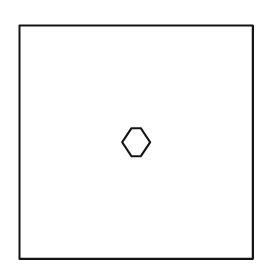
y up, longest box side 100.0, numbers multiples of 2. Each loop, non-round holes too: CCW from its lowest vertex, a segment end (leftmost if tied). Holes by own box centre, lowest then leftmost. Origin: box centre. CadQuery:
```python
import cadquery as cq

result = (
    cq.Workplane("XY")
    .moveTo(-50.0, -50.0)
    .lineTo(50.0, -50.0)
    .lineTo(50.0, 50.0)
    .lineTo(-50.0, 50.0)
    .close()
    .moveTo(-2.0, -6.0)
    .lineTo(2.0, -6.0)
    .lineTo(6.0, 0.0)
    .lineTo(2.0, 6.0)
    .lineTo(-2.0, 6.0)
    .lineTo(-6.0, 0.0)
    .close()
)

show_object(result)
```